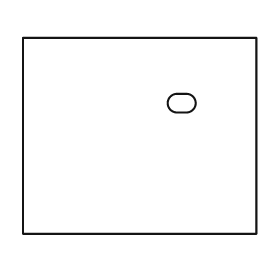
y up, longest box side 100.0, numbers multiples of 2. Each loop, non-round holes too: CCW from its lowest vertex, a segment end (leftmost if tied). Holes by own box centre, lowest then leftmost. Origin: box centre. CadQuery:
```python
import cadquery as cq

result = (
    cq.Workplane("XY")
    .moveTo(-50.0, -42.0)
    .lineTo(50.0, -42.0)
    .lineTo(50.0, 42.0)
    .lineTo(-50.0, 42.0)
    .close()
    .moveTo(16.0, 10.0)
    .lineTo(20.0, 10.0)
    .threePointArc((24.0, 14.0), (20.0, 18.0))
    .lineTo(16.0, 18.0)
    .threePointArc((12.0, 14.0), (16.0, 10.0))
    .close()
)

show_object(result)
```